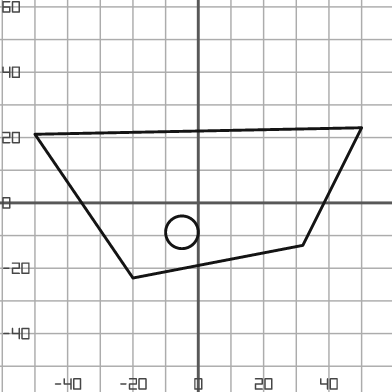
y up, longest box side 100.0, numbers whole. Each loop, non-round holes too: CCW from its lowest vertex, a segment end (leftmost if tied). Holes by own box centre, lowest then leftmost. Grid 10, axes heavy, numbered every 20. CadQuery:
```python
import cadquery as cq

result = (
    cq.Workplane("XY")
    .moveTo(-20.0, -23.0)
    .lineTo(32.0, -13.0)
    .lineTo(50.0, 23.0)
    .lineTo(-50.0, 21.0)
    .close()
    .moveTo(-5.0, -9.0)
    .circle(5.0)
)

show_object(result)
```